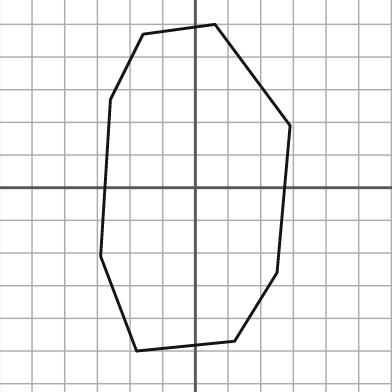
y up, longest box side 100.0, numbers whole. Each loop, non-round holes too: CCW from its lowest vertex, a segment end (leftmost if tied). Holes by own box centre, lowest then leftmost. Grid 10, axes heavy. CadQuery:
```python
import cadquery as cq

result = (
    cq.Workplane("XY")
    .moveTo(-18.0, -50.0)
    .lineTo(12.0, -47.0)
    .lineTo(25.0, -26.0)
    .lineTo(29.0, 19.0)
    .lineTo(6.0, 50.0)
    .lineTo(-16.0, 47.0)
    .lineTo(-26.0, 27.0)
    .lineTo(-29.0, -21.0)
    .close()
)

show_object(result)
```